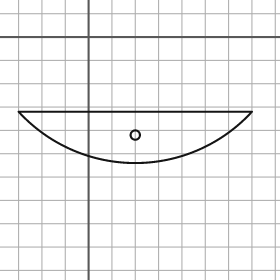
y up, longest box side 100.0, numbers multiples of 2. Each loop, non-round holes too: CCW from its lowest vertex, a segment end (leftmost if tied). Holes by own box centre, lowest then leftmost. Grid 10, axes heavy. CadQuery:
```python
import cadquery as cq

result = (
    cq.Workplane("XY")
    .moveTo(-30.0, -32.0)
    .threePointArc((20.0, -54.0), (70.0, -32.0))
    .close()
    .moveTo(20.0, -42.0)
    .circle(2.0)
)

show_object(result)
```